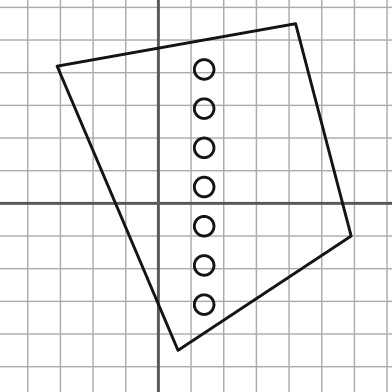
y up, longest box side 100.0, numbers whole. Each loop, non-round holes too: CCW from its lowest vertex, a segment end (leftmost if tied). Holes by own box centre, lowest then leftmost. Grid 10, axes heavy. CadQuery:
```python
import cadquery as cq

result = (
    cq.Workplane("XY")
    .moveTo(6.0, -45.0)
    .lineTo(59.0, -10.0)
    .lineTo(42.0, 55.0)
    .lineTo(-31.0, 42.0)
    .close()
    .moveTo(14.0, -31.0)
    .circle(3.0)
    .moveTo(14.0, -19.0)
    .circle(3.0)
    .moveTo(14.0, -7.0)
    .circle(3.0)
    .moveTo(14.0, 5.0)
    .circle(3.0)
    .moveTo(14.0, 17.0)
    .circle(3.0)
    .moveTo(14.0, 29.0)
    .circle(3.0)
    .moveTo(14.0, 41.0)
    .circle(3.0)
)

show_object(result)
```